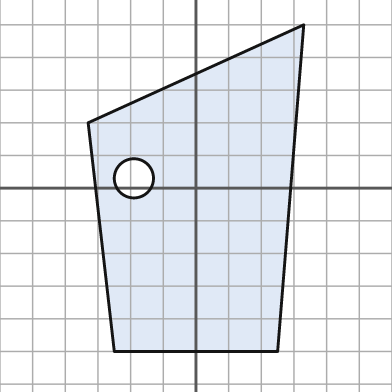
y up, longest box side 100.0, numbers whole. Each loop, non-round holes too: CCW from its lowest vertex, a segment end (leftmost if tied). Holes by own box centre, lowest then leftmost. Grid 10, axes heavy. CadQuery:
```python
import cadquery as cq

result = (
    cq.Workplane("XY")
    .moveTo(-25.0, -50.0)
    .lineTo(25.0, -50.0)
    .lineTo(33.0, 50.0)
    .lineTo(-33.0, 20.0)
    .close()
    .moveTo(-19.0, 3.0)
    .circle(6.0)
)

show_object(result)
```